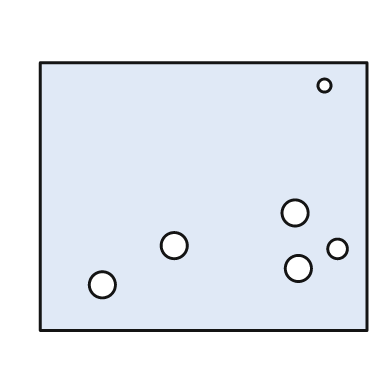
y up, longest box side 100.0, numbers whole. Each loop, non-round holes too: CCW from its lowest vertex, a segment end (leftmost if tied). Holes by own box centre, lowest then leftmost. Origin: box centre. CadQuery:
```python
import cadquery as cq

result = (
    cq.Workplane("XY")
    .moveTo(-50.0, -41.0)
    .lineTo(50.0, -41.0)
    .lineTo(50.0, 41.0)
    .lineTo(-50.0, 41.0)
    .close()
    .moveTo(-31.0, -27.0)
    .circle(4.0)
    .moveTo(29.0, -22.0)
    .circle(4.0)
    .moveTo(41.0, -16.0)
    .circle(3.0)
    .moveTo(-9.0, -15.0)
    .circle(4.0)
    .moveTo(28.0, -5.0)
    .circle(4.0)
    .moveTo(37.0, 34.0)
    .circle(2.0)
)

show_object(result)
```